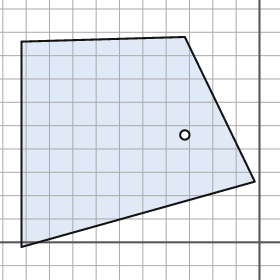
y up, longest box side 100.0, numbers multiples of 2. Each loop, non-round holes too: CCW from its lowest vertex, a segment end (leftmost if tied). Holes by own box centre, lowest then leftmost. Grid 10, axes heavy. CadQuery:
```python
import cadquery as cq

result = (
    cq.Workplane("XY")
    .moveTo(-102.0, -2.0)
    .lineTo(-2.0, 26.0)
    .lineTo(-32.0, 88.0)
    .lineTo(-102.0, 86.0)
    .close()
    .moveTo(-32.0, 46.0)
    .circle(2.0)
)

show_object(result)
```